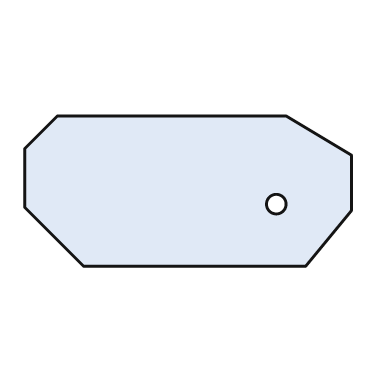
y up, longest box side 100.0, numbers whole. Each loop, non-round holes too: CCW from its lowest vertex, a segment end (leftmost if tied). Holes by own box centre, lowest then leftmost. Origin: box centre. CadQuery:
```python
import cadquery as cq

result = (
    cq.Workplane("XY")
    .moveTo(-32.0, -23.0)
    .lineTo(36.0, -23.0)
    .lineTo(50.0, -6.0)
    .lineTo(50.0, 11.0)
    .lineTo(30.0, 23.0)
    .lineTo(-40.0, 23.0)
    .lineTo(-50.0, 13.0)
    .lineTo(-50.0, -5.0)
    .close()
    .moveTo(27.0, -4.0)
    .circle(3.0)
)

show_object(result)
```